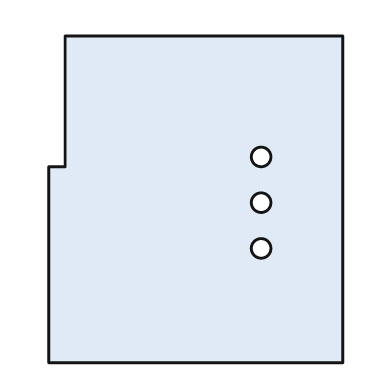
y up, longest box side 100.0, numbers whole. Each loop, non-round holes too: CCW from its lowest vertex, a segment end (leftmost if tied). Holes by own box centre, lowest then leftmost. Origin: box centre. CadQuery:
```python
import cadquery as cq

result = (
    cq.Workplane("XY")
    .moveTo(-45.0, -50.0)
    .lineTo(45.0, -50.0)
    .lineTo(45.0, 50.0)
    .lineTo(-40.0, 50.0)
    .lineTo(-40.0, 10.0)
    .lineTo(-45.0, 10.0)
    .close()
    .moveTo(20.0, -15.0)
    .circle(3.0)
    .moveTo(20.0, -1.0)
    .circle(3.0)
    .moveTo(20.0, 13.0)
    .circle(3.0)
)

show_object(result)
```